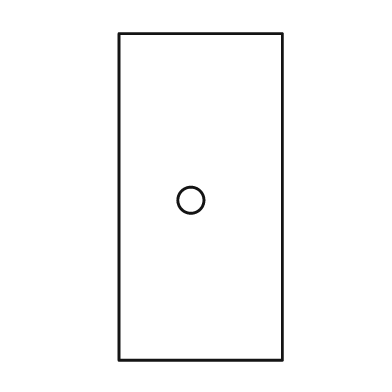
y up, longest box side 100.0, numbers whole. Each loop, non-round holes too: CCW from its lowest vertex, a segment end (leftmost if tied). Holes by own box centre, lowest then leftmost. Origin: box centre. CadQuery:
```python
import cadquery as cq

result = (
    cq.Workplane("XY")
    .moveTo(-25.0, -50.0)
    .lineTo(25.0, -50.0)
    .lineTo(25.0, 50.0)
    .lineTo(-25.0, 50.0)
    .close()
    .moveTo(-3.0, -1.0)
    .circle(4.0)
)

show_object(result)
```